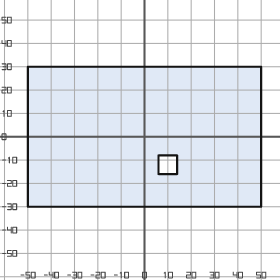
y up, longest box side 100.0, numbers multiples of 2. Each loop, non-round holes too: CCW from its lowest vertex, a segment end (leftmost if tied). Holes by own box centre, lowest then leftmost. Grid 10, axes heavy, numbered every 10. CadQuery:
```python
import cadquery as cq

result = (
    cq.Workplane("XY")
    .moveTo(-50.0, -30.0)
    .lineTo(50.0, -30.0)
    .lineTo(50.0, 30.0)
    .lineTo(-50.0, 30.0)
    .close()
    .moveTo(6.0, -16.0)
    .lineTo(14.0, -16.0)
    .lineTo(14.0, -8.0)
    .lineTo(6.0, -8.0)
    .close()
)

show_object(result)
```